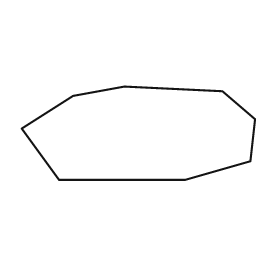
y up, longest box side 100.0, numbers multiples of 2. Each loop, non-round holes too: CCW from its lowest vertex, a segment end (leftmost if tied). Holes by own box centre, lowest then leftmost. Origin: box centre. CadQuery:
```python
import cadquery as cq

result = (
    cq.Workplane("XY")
    .moveTo(-34.0, -20.0)
    .lineTo(20.0, -20.0)
    .lineTo(48.0, -12.0)
    .lineTo(50.0, 6.0)
    .lineTo(36.0, 18.0)
    .lineTo(-6.0, 20.0)
    .lineTo(-28.0, 16.0)
    .lineTo(-50.0, 2.0)
    .close()
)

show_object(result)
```